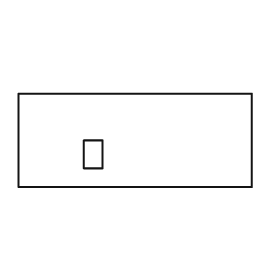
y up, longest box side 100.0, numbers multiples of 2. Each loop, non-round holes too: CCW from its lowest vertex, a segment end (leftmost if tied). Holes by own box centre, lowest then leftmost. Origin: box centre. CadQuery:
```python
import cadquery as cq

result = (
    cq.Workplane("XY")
    .moveTo(-50.0, -20.0)
    .lineTo(50.0, -20.0)
    .lineTo(50.0, 20.0)
    .lineTo(-50.0, 20.0)
    .close()
    .moveTo(-22.0, -12.0)
    .lineTo(-14.0, -12.0)
    .lineTo(-14.0, 0.0)
    .lineTo(-22.0, 0.0)
    .close()
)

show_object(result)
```